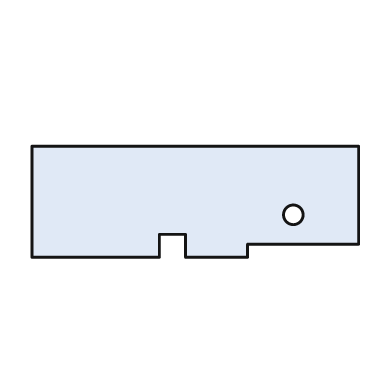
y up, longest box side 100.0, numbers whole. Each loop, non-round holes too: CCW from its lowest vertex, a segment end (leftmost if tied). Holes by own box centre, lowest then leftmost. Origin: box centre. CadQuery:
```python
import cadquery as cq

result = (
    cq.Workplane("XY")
    .moveTo(-50.0, -17.0)
    .lineTo(-11.0, -17.0)
    .lineTo(-11.0, -10.0)
    .lineTo(-3.0, -10.0)
    .lineTo(-3.0, -17.0)
    .lineTo(16.0, -17.0)
    .lineTo(16.0, -13.0)
    .lineTo(50.0, -13.0)
    .lineTo(50.0, 17.0)
    .lineTo(-50.0, 17.0)
    .close()
    .moveTo(30.0, -4.0)
    .circle(3.0)
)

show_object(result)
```